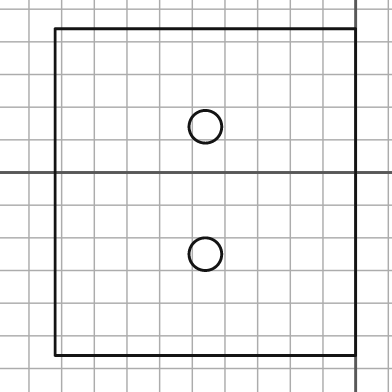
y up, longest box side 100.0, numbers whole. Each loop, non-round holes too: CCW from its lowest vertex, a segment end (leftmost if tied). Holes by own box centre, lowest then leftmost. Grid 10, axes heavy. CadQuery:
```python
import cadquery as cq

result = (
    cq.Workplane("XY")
    .moveTo(-92.0, -56.0)
    .lineTo(0.0, -56.0)
    .lineTo(0.0, 44.0)
    .lineTo(-92.0, 44.0)
    .close()
    .moveTo(-46.0, -25.0)
    .circle(5.0)
    .moveTo(-46.0, 14.0)
    .circle(5.0)
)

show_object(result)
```